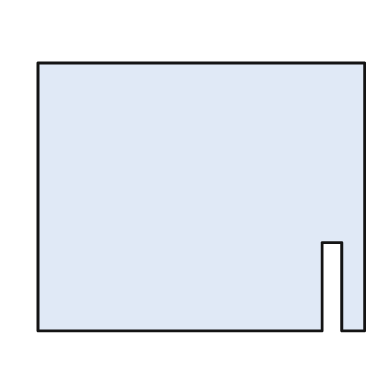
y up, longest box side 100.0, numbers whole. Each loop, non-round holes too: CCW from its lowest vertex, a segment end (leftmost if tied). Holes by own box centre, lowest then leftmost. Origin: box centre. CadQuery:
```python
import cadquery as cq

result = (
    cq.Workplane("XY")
    .moveTo(-50.0, -41.0)
    .lineTo(37.0, -41.0)
    .lineTo(37.0, -14.0)
    .lineTo(43.0, -14.0)
    .lineTo(43.0, -41.0)
    .lineTo(50.0, -41.0)
    .lineTo(50.0, 41.0)
    .lineTo(-50.0, 41.0)
    .close()
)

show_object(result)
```